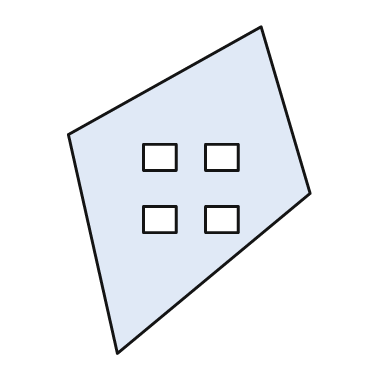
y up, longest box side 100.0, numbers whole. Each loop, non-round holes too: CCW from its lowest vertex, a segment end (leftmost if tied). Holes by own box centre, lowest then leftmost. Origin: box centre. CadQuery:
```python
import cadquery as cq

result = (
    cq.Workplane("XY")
    .moveTo(-22.0, -50.0)
    .lineTo(37.0, -1.0)
    .lineTo(22.0, 50.0)
    .lineTo(-37.0, 17.0)
    .close()
    .moveTo(-14.0, -13.0)
    .lineTo(-4.0, -13.0)
    .lineTo(-4.0, -5.0)
    .lineTo(-14.0, -5.0)
    .close()
    .moveTo(5.0, -13.0)
    .lineTo(15.0, -13.0)
    .lineTo(15.0, -5.0)
    .lineTo(5.0, -5.0)
    .close()
    .moveTo(-14.0, 6.0)
    .lineTo(-4.0, 6.0)
    .lineTo(-4.0, 14.0)
    .lineTo(-14.0, 14.0)
    .close()
    .moveTo(5.0, 6.0)
    .lineTo(15.0, 6.0)
    .lineTo(15.0, 14.0)
    .lineTo(5.0, 14.0)
    .close()
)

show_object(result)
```